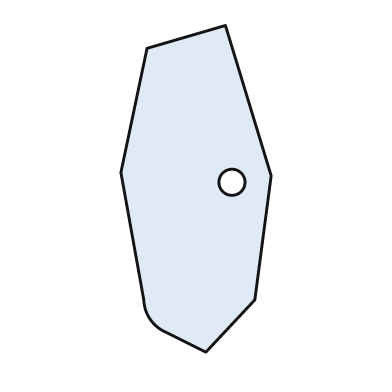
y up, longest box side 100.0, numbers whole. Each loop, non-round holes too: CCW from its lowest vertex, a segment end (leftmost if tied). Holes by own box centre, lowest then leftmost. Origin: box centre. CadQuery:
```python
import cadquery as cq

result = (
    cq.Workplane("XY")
    .moveTo(3.0, -50.0)
    .lineTo(18.0, -34.0)
    .lineTo(23.0, 4.0)
    .lineTo(9.0, 50.0)
    .lineTo(-15.0, 43.0)
    .lineTo(-23.0, 5.0)
    .lineTo(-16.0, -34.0)
    .threePointArc((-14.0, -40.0), (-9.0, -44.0))
    .close()
    .moveTo(11.0, 2.0)
    .circle(4.0)
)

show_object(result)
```